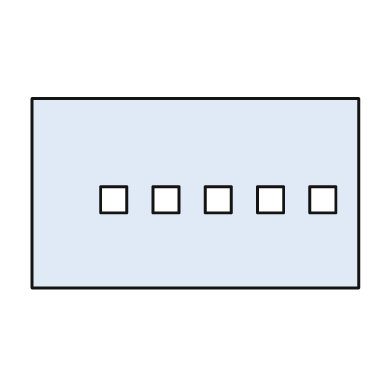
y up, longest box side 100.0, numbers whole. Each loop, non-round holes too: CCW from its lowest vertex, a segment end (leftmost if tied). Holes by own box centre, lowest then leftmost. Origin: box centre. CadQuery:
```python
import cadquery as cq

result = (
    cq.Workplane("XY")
    .moveTo(-50.0, -29.0)
    .lineTo(50.0, -29.0)
    .lineTo(50.0, 29.0)
    .lineTo(-50.0, 29.0)
    .close()
    .moveTo(-29.0, -6.0)
    .lineTo(-21.0, -6.0)
    .lineTo(-21.0, 2.0)
    .lineTo(-29.0, 2.0)
    .close()
    .moveTo(-13.0, -6.0)
    .lineTo(-5.0, -6.0)
    .lineTo(-5.0, 2.0)
    .lineTo(-13.0, 2.0)
    .close()
    .moveTo(3.0, -6.0)
    .lineTo(11.0, -6.0)
    .lineTo(11.0, 2.0)
    .lineTo(3.0, 2.0)
    .close()
    .moveTo(19.0, -6.0)
    .lineTo(27.0, -6.0)
    .lineTo(27.0, 2.0)
    .lineTo(19.0, 2.0)
    .close()
    .moveTo(35.0, -6.0)
    .lineTo(43.0, -6.0)
    .lineTo(43.0, 2.0)
    .lineTo(35.0, 2.0)
    .close()
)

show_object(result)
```